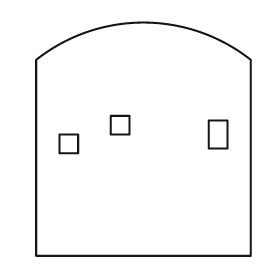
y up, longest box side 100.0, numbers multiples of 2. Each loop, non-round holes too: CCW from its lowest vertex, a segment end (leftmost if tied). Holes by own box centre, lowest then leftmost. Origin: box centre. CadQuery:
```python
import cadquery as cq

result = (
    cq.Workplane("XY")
    .moveTo(-46.0, -50.0)
    .lineTo(46.0, -50.0)
    .lineTo(46.0, 34.0)
    .threePointArc((0.0, 50.0), (-46.0, 34.0))
    .close()
    .moveTo(-36.0, -6.0)
    .lineTo(-28.0, -6.0)
    .lineTo(-28.0, 2.0)
    .lineTo(-36.0, 2.0)
    .close()
    .moveTo(28.0, -4.0)
    .lineTo(36.0, -4.0)
    .lineTo(36.0, 8.0)
    .lineTo(28.0, 8.0)
    .close()
    .moveTo(-14.0, 2.0)
    .lineTo(-6.0, 2.0)
    .lineTo(-6.0, 10.0)
    .lineTo(-14.0, 10.0)
    .close()
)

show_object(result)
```